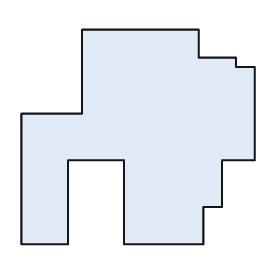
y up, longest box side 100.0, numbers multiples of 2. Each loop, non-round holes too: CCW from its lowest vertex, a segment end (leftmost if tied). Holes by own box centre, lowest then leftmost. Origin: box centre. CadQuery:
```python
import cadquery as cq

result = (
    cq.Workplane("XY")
    .moveTo(-50.0, -46.0)
    .lineTo(-30.0, -46.0)
    .lineTo(-30.0, -10.0)
    .lineTo(-6.0, -10.0)
    .lineTo(-6.0, -46.0)
    .lineTo(28.0, -46.0)
    .lineTo(28.0, -30.0)
    .lineTo(36.0, -30.0)
    .lineTo(36.0, -10.0)
    .lineTo(50.0, -10.0)
    .lineTo(50.0, 30.0)
    .lineTo(42.0, 30.0)
    .lineTo(42.0, 34.0)
    .lineTo(26.0, 34.0)
    .lineTo(26.0, 46.0)
    .lineTo(-24.0, 46.0)
    .lineTo(-24.0, 10.0)
    .lineTo(-50.0, 10.0)
    .close()
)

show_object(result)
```